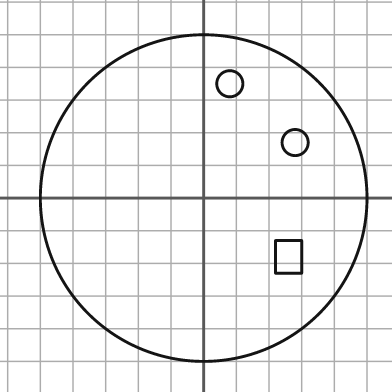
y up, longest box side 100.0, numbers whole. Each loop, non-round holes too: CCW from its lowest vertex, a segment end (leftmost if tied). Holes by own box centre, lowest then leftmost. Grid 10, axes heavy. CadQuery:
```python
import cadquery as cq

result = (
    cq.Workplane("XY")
    .moveTo(0.0, 0.0)
    .circle(50.0)
    .moveTo(22.0, -23.0)
    .lineTo(30.0, -23.0)
    .lineTo(30.0, -13.0)
    .lineTo(22.0, -13.0)
    .close()
    .moveTo(28.0, 17.0)
    .circle(4.0)
    .moveTo(8.0, 35.0)
    .circle(4.0)
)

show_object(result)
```